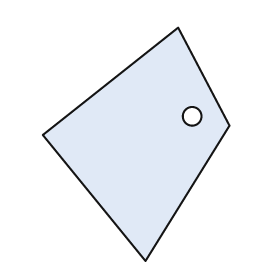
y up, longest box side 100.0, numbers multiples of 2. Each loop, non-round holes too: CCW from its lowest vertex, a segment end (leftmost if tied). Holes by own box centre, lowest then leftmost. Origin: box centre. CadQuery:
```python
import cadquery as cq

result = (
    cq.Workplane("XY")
    .moveTo(4.0, -50.0)
    .lineTo(40.0, 8.0)
    .lineTo(18.0, 50.0)
    .lineTo(-40.0, 4.0)
    .close()
    .moveTo(24.0, 12.0)
    .circle(4.0)
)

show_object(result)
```